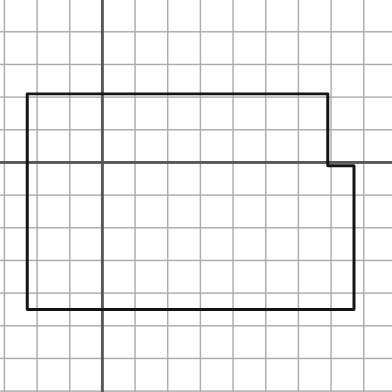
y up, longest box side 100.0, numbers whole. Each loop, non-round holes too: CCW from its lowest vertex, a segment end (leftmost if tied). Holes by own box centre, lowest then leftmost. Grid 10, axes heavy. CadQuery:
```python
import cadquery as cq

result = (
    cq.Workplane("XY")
    .moveTo(-23.0, -45.0)
    .lineTo(77.0, -45.0)
    .lineTo(77.0, -1.0)
    .lineTo(69.0, -1.0)
    .lineTo(69.0, 21.0)
    .lineTo(-23.0, 21.0)
    .close()
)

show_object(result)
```